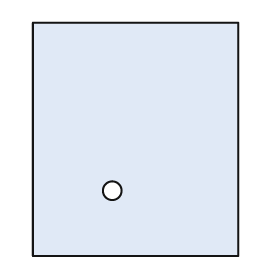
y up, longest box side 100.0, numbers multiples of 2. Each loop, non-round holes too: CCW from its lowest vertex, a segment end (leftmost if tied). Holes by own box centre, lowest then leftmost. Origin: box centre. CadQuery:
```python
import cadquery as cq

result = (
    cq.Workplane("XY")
    .moveTo(-44.0, -50.0)
    .lineTo(44.0, -50.0)
    .lineTo(44.0, 50.0)
    .lineTo(-44.0, 50.0)
    .close()
    .moveTo(-10.0, -22.0)
    .circle(4.0)
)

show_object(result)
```